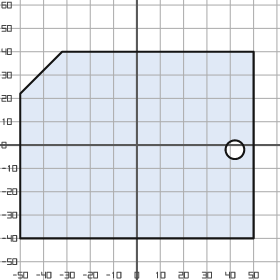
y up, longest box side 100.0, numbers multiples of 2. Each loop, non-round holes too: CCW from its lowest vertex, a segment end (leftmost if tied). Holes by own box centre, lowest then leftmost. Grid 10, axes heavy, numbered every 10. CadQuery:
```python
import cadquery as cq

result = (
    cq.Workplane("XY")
    .moveTo(-50.0, -40.0)
    .lineTo(50.0, -40.0)
    .lineTo(50.0, 40.0)
    .lineTo(-32.0, 40.0)
    .lineTo(-50.0, 22.0)
    .close()
    .moveTo(42.0, -2.0)
    .circle(4.0)
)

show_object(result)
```